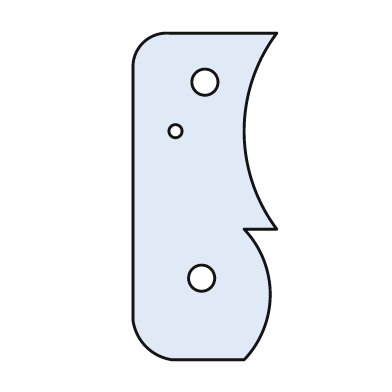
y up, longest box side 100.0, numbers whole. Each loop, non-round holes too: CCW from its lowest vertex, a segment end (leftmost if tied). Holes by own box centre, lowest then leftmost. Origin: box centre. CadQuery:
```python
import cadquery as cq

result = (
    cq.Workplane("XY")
    .moveTo(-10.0, -50.0)
    .lineTo(12.0, -50.0)
    .threePointArc((20.0, -30.0), (12.0, -10.0))
    .lineTo(22.0, -10.0)
    .threePointArc((12.0, 20.0), (22.0, 50.0))
    .lineTo(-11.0, 50.0)
    .threePointArc((-19.0, 47.0), (-22.0, 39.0))
    .lineTo(-22.0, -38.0)
    .threePointArc((-18.0, -46.0), (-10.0, -50.0))
    .close()
    .moveTo(-1.0, -25.0)
    .circle(4.0)
    .moveTo(-9.0, 20.0)
    .circle(2.0)
    .moveTo(0.0, 35.0)
    .circle(4.0)
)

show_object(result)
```